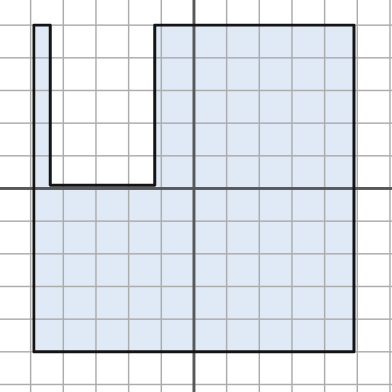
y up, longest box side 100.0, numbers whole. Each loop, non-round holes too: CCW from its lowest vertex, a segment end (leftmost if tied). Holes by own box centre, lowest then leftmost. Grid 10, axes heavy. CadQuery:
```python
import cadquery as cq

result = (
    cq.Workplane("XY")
    .moveTo(-49.0, -50.0)
    .lineTo(49.0, -50.0)
    .lineTo(49.0, 50.0)
    .lineTo(-12.0, 50.0)
    .lineTo(-12.0, 1.0)
    .lineTo(-44.0, 1.0)
    .lineTo(-44.0, 50.0)
    .lineTo(-49.0, 50.0)
    .close()
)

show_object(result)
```